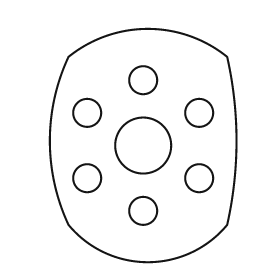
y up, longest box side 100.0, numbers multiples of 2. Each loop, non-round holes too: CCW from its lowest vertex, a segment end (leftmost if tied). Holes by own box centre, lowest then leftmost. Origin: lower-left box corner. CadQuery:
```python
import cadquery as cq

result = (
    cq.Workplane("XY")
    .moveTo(8.0, 16.0)
    .threePointArc((42.0, 0.0), (76.0, 16.0))
    .threePointArc((80.0, 52.0), (76.0, 88.0))
    .threePointArc((42.0, 100.0), (8.0, 88.0))
    .threePointArc((0.0, 52.0), (8.0, 16.0))
    .close()
    .moveTo(40.0, 22.0)
    .circle(6.0)
    .moveTo(16.0, 36.0)
    .circle(6.0)
    .moveTo(64.0, 36.0)
    .circle(6.0)
    .moveTo(40.0, 50.0)
    .circle(12.0)
    .moveTo(16.0, 64.0)
    .circle(6.0)
    .moveTo(64.0, 64.0)
    .circle(6.0)
    .moveTo(40.0, 78.0)
    .circle(6.0)
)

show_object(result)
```